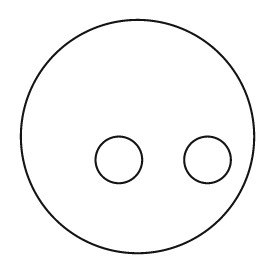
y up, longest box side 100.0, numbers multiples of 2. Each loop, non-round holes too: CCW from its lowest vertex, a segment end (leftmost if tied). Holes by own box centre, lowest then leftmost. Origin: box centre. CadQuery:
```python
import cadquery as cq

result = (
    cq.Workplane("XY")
    .moveTo(0.0, 0.0)
    .circle(50.0)
    .moveTo(-8.0, -10.0)
    .circle(10.0)
    .moveTo(30.0, -10.0)
    .circle(10.0)
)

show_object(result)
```